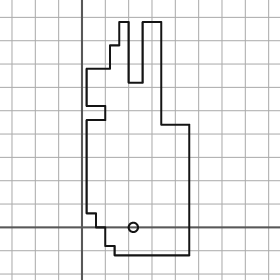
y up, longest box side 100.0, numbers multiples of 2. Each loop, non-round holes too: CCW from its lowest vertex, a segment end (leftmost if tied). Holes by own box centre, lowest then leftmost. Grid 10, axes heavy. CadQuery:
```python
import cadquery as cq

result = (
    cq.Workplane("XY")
    .moveTo(14.0, -12.0)
    .lineTo(46.0, -12.0)
    .lineTo(46.0, 44.0)
    .lineTo(34.0, 44.0)
    .lineTo(34.0, 88.0)
    .lineTo(26.0, 88.0)
    .lineTo(26.0, 62.0)
    .lineTo(20.0, 62.0)
    .lineTo(20.0, 88.0)
    .lineTo(16.0, 88.0)
    .lineTo(16.0, 78.0)
    .lineTo(12.0, 78.0)
    .lineTo(12.0, 68.0)
    .lineTo(2.0, 68.0)
    .lineTo(2.0, 52.0)
    .lineTo(10.0, 52.0)
    .lineTo(10.0, 46.0)
    .lineTo(2.0, 46.0)
    .lineTo(2.0, 6.0)
    .lineTo(6.0, 6.0)
    .lineTo(6.0, 0.0)
    .lineTo(10.0, 0.0)
    .lineTo(10.0, -8.0)
    .lineTo(14.0, -8.0)
    .close()
    .moveTo(22.0, 0.0)
    .circle(2.0)
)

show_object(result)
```